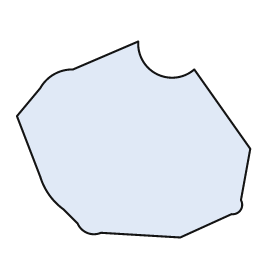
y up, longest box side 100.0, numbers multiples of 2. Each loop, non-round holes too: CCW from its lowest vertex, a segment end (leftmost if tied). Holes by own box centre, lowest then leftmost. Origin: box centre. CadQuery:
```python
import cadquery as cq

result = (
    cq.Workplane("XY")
    .moveTo(20.0, -42.0)
    .lineTo(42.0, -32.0)
    .threePointArc((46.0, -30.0), (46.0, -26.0))
    .lineTo(50.0, -4.0)
    .lineTo(26.0, 30.0)
    .threePointArc((10.0, 28.0), (2.0, 42.0))
    .lineTo(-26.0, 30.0)
    .threePointArc((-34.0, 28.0), (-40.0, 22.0))
    .lineTo(-50.0, 10.0)
    .lineTo(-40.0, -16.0)
    .threePointArc((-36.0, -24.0), (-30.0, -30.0))
    .lineTo(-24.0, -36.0)
    .threePointArc((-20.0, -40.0), (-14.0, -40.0))
    .close()
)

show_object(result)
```